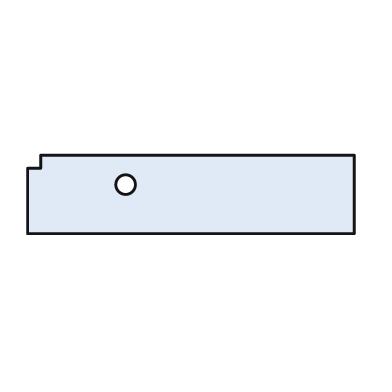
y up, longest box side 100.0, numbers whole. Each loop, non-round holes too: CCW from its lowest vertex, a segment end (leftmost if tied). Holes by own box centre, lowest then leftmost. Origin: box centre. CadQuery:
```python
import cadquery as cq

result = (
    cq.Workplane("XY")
    .moveTo(-50.0, -12.0)
    .lineTo(50.0, -12.0)
    .lineTo(50.0, 12.0)
    .lineTo(-46.0, 12.0)
    .lineTo(-46.0, 8.0)
    .lineTo(-50.0, 8.0)
    .close()
    .moveTo(-20.0, 3.0)
    .circle(3.0)
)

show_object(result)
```